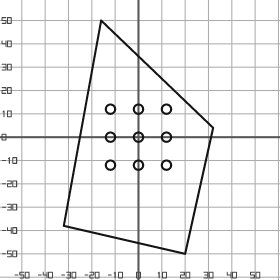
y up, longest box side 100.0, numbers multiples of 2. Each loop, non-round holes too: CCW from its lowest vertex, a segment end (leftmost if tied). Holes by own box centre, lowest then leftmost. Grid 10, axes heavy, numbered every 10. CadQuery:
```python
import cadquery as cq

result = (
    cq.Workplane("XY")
    .moveTo(20.0, -50.0)
    .lineTo(32.0, 4.0)
    .lineTo(-16.0, 50.0)
    .lineTo(-32.0, -38.0)
    .close()
    .moveTo(-12.0, -12.0)
    .circle(2.0)
    .moveTo(0.0, -12.0)
    .circle(2.0)
    .moveTo(12.0, -12.0)
    .circle(2.0)
    .moveTo(-12.0, 0.0)
    .circle(2.0)
    .moveTo(0.0, 0.0)
    .circle(2.0)
    .moveTo(12.0, 0.0)
    .circle(2.0)
    .moveTo(-12.0, 12.0)
    .circle(2.0)
    .moveTo(0.0, 12.0)
    .circle(2.0)
    .moveTo(12.0, 12.0)
    .circle(2.0)
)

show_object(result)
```